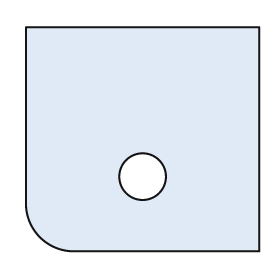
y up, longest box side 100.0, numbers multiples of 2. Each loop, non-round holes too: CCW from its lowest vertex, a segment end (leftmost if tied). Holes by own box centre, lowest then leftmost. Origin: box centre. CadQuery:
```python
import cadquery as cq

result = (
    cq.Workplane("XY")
    .moveTo(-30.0, -48.0)
    .lineTo(50.0, -48.0)
    .lineTo(50.0, 48.0)
    .lineTo(-50.0, 48.0)
    .lineTo(-50.0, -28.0)
    .threePointArc((-44.0, -42.0), (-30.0, -48.0))
    .close()
    .moveTo(0.0, -16.0)
    .circle(10.0)
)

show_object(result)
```